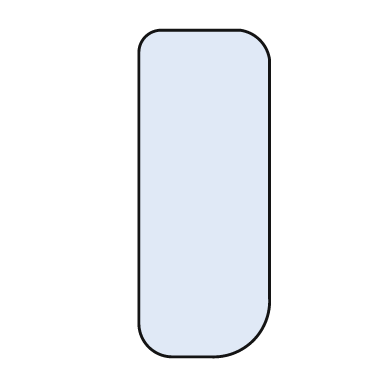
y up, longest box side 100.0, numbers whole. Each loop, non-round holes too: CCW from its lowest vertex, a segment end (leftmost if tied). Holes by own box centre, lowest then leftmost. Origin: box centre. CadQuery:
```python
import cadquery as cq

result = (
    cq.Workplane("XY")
    .moveTo(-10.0, -50.0)
    .lineTo(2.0, -50.0)
    .threePointArc((15.0, -45.0), (20.0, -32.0))
    .lineTo(20.0, 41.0)
    .threePointArc((17.0, 47.0), (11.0, 50.0))
    .lineTo(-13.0, 50.0)
    .threePointArc((-18.0, 48.0), (-20.0, 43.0))
    .lineTo(-20.0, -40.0)
    .threePointArc((-17.0, -47.0), (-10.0, -50.0))
    .close()
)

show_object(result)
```